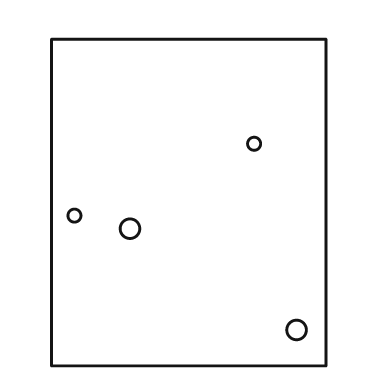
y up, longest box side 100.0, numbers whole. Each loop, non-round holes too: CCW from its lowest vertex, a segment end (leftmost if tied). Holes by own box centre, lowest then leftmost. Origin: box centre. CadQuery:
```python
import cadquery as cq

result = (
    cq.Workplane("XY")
    .moveTo(-42.0, -50.0)
    .lineTo(42.0, -50.0)
    .lineTo(42.0, 50.0)
    .lineTo(-42.0, 50.0)
    .close()
    .moveTo(33.0, -39.0)
    .circle(3.0)
    .moveTo(-18.0, -8.0)
    .circle(3.0)
    .moveTo(-35.0, -4.0)
    .circle(2.0)
    .moveTo(20.0, 18.0)
    .circle(2.0)
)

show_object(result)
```